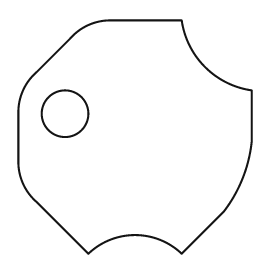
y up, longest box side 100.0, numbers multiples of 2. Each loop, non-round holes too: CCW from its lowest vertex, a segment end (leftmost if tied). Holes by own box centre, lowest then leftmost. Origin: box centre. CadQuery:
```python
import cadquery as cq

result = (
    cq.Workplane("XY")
    .moveTo(-20.0, -50.0)
    .threePointArc((0.0, -42.0), (20.0, -50.0))
    .lineTo(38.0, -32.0)
    .threePointArc((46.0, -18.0), (50.0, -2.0))
    .lineTo(50.0, 20.0)
    .threePointArc((30.0, 30.0), (20.0, 50.0))
    .lineTo(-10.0, 50.0)
    .threePointArc((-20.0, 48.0), (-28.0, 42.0))
    .lineTo(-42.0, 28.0)
    .threePointArc((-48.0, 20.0), (-50.0, 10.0))
    .lineTo(-50.0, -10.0)
    .threePointArc((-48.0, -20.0), (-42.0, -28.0))
    .close()
    .moveTo(-30.0, 10.0)
    .circle(10.0)
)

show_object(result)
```